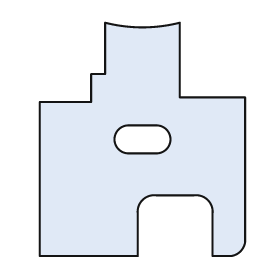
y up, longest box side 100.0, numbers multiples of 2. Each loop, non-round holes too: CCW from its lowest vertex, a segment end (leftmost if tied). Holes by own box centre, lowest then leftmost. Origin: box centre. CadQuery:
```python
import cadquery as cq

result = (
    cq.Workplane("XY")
    .moveTo(-44.0, -50.0)
    .lineTo(-2.0, -50.0)
    .lineTo(-2.0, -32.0)
    .threePointArc((0.0, -26.0), (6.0, -24.0))
    .lineTo(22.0, -24.0)
    .threePointArc((28.0, -26.0), (30.0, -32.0))
    .lineTo(30.0, -50.0)
    .lineTo(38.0, -50.0)
    .threePointArc((42.0, -48.0), (44.0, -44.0))
    .lineTo(44.0, 18.0)
    .lineTo(16.0, 18.0)
    .lineTo(16.0, 50.0)
    .threePointArc((0.0, 48.0), (-16.0, 50.0))
    .lineTo(-16.0, 28.0)
    .lineTo(-22.0, 28.0)
    .lineTo(-22.0, 16.0)
    .lineTo(-44.0, 16.0)
    .close()
    .moveTo(-6.0, -6.0)
    .lineTo(6.0, -6.0)
    .threePointArc((12.0, 0.0), (6.0, 6.0))
    .lineTo(-6.0, 6.0)
    .threePointArc((-12.0, 0.0), (-6.0, -6.0))
    .close()
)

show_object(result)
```